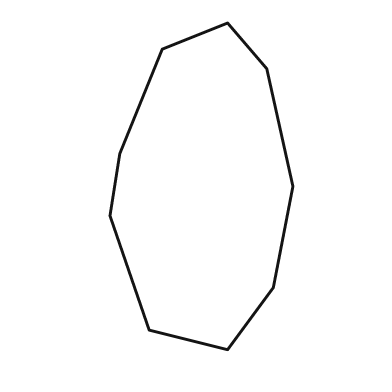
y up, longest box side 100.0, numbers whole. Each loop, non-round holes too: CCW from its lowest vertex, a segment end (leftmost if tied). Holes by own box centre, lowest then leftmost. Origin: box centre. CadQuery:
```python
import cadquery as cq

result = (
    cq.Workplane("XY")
    .moveTo(8.0, -50.0)
    .lineTo(22.0, -31.0)
    .lineTo(28.0, 0.0)
    .lineTo(20.0, 36.0)
    .lineTo(8.0, 50.0)
    .lineTo(-12.0, 42.0)
    .lineTo(-25.0, 10.0)
    .lineTo(-28.0, -9.0)
    .lineTo(-16.0, -44.0)
    .close()
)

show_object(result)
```